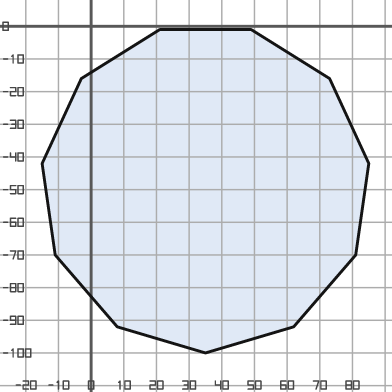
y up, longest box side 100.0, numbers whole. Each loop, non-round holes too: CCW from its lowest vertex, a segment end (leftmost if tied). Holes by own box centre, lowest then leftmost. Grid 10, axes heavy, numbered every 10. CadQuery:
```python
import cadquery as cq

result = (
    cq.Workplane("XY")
    .moveTo(35.0, -100.0)
    .lineTo(62.0, -92.0)
    .lineTo(81.0, -70.0)
    .lineTo(85.0, -42.0)
    .lineTo(73.0, -16.0)
    .lineTo(49.0, -1.0)
    .lineTo(21.0, -1.0)
    .lineTo(-3.0, -16.0)
    .lineTo(-15.0, -42.0)
    .lineTo(-11.0, -70.0)
    .lineTo(8.0, -92.0)
    .close()
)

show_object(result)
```